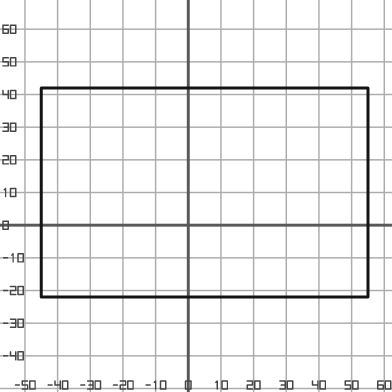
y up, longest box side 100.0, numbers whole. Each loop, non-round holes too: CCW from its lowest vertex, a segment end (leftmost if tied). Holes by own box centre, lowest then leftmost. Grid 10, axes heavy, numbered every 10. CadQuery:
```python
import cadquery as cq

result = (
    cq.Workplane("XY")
    .moveTo(-45.0, -22.0)
    .lineTo(55.0, -22.0)
    .lineTo(55.0, 42.0)
    .lineTo(-45.0, 42.0)
    .close()
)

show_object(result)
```